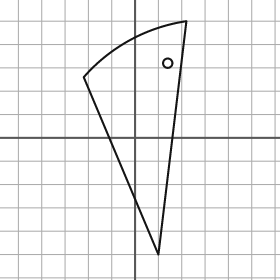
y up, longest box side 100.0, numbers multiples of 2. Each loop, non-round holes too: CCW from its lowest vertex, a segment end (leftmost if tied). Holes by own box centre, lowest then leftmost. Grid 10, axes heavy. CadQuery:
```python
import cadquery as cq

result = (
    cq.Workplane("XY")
    .moveTo(10.0, -50.0)
    .lineTo(22.0, 50.0)
    .threePointArc((-2.0, 42.0), (-22.0, 26.0))
    .close()
    .moveTo(14.0, 32.0)
    .circle(2.0)
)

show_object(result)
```